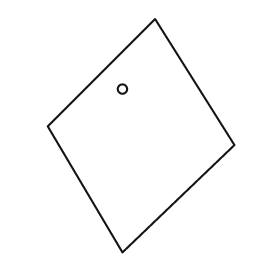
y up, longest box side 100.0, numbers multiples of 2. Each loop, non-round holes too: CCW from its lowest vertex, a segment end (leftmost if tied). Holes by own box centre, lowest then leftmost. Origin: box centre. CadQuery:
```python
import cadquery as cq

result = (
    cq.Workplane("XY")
    .moveTo(-8.0, -50.0)
    .lineTo(40.0, -4.0)
    .lineTo(6.0, 50.0)
    .lineTo(-40.0, 4.0)
    .close()
    .moveTo(-8.0, 20.0)
    .circle(2.0)
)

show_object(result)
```